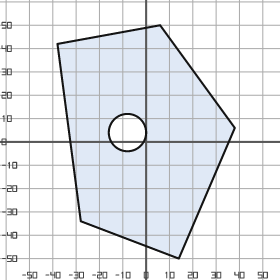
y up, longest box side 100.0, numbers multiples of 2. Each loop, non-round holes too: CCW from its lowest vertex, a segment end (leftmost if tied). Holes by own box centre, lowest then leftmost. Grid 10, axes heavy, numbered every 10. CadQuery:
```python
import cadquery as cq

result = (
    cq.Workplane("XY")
    .moveTo(14.0, -50.0)
    .lineTo(38.0, 6.0)
    .lineTo(6.0, 50.0)
    .lineTo(-38.0, 42.0)
    .lineTo(-28.0, -34.0)
    .close()
    .moveTo(-8.0, 4.0)
    .circle(8.0)
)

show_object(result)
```